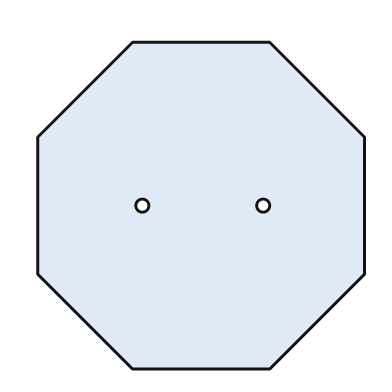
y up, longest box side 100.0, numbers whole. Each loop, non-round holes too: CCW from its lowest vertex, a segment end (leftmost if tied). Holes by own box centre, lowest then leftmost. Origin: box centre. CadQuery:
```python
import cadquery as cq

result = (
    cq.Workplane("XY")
    .moveTo(-21.0, -50.0)
    .lineTo(21.0, -50.0)
    .lineTo(50.0, -21.0)
    .lineTo(50.0, 21.0)
    .lineTo(21.0, 50.0)
    .lineTo(-21.0, 50.0)
    .lineTo(-50.0, 21.0)
    .lineTo(-50.0, -21.0)
    .close()
    .moveTo(-18.0, 0.0)
    .circle(2.0)
    .moveTo(19.0, 0.0)
    .circle(2.0)
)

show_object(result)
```